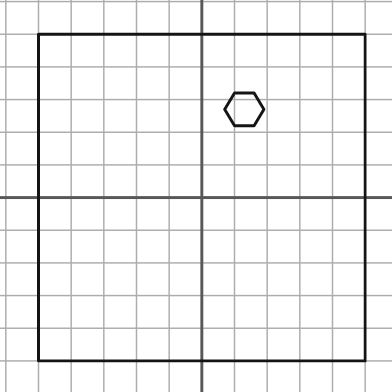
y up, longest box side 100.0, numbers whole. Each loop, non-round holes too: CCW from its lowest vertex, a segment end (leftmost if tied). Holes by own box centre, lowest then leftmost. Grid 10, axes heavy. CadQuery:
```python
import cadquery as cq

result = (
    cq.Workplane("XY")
    .moveTo(-50.0, -50.0)
    .lineTo(50.0, -50.0)
    .lineTo(50.0, 50.0)
    .lineTo(-50.0, 50.0)
    .close()
    .moveTo(10.0, 22.0)
    .lineTo(16.0, 22.0)
    .lineTo(19.0, 27.0)
    .lineTo(16.0, 32.0)
    .lineTo(10.0, 32.0)
    .lineTo(7.0, 27.0)
    .close()
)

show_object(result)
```